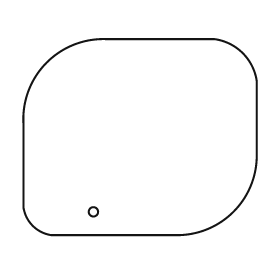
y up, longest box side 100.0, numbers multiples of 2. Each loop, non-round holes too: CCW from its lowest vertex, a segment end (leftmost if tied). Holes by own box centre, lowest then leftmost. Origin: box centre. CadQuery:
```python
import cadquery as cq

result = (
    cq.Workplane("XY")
    .moveTo(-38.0, -42.0)
    .lineTo(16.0, -42.0)
    .threePointArc((40.0, -32.0), (50.0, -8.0))
    .lineTo(50.0, 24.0)
    .threePointArc((44.0, 36.0), (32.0, 42.0))
    .lineTo(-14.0, 42.0)
    .threePointArc((-40.0, 32.0), (-50.0, 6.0))
    .lineTo(-50.0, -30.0)
    .threePointArc((-46.0, -38.0), (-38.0, -42.0))
    .close()
    .moveTo(-20.0, -32.0)
    .circle(2.0)
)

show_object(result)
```